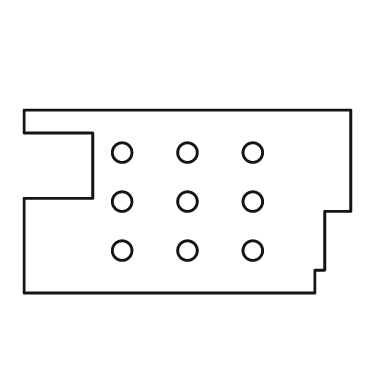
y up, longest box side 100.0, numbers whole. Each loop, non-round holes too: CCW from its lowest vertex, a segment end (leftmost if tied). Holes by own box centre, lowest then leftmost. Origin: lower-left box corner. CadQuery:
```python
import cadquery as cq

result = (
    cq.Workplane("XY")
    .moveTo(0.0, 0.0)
    .lineTo(89.0, 0.0)
    .lineTo(89.0, 7.0)
    .lineTo(92.0, 7.0)
    .lineTo(92.0, 25.0)
    .lineTo(100.0, 25.0)
    .lineTo(100.0, 56.0)
    .lineTo(0.0, 56.0)
    .lineTo(0.0, 49.0)
    .lineTo(21.0, 49.0)
    .lineTo(21.0, 29.0)
    .lineTo(0.0, 29.0)
    .close()
    .moveTo(30.0, 13.0)
    .circle(3.0)
    .moveTo(50.0, 13.0)
    .circle(3.0)
    .moveTo(70.0, 13.0)
    .circle(3.0)
    .moveTo(30.0, 28.0)
    .circle(3.0)
    .moveTo(50.0, 28.0)
    .circle(3.0)
    .moveTo(70.0, 28.0)
    .circle(3.0)
    .moveTo(30.0, 43.0)
    .circle(3.0)
    .moveTo(50.0, 43.0)
    .circle(3.0)
    .moveTo(70.0, 43.0)
    .circle(3.0)
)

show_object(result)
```